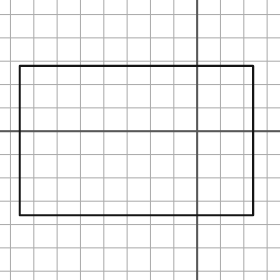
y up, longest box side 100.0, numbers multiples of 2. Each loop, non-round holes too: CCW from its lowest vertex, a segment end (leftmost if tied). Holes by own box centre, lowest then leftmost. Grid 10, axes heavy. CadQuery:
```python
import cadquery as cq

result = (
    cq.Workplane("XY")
    .moveTo(-76.0, -36.0)
    .lineTo(24.0, -36.0)
    .lineTo(24.0, 28.0)
    .lineTo(-76.0, 28.0)
    .close()
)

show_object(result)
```